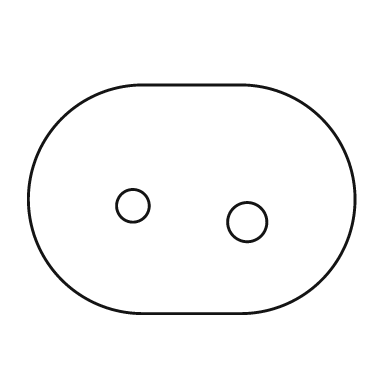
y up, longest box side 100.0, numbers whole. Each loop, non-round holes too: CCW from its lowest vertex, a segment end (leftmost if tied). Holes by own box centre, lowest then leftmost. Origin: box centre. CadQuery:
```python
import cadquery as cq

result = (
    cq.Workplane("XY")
    .moveTo(-15.0, -35.0)
    .lineTo(15.0, -35.0)
    .threePointArc((50.0, 0.0), (15.0, 35.0))
    .lineTo(-15.0, 35.0)
    .threePointArc((-50.0, 0.0), (-15.0, -35.0))
    .close()
    .moveTo(17.0, -7.0)
    .circle(6.0)
    .moveTo(-18.0, -2.0)
    .circle(5.0)
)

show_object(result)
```